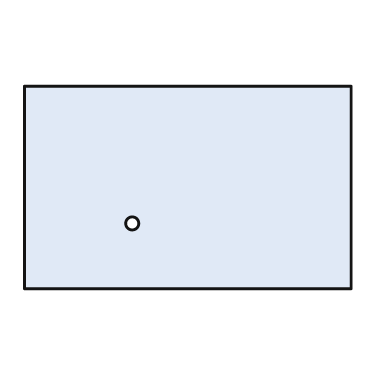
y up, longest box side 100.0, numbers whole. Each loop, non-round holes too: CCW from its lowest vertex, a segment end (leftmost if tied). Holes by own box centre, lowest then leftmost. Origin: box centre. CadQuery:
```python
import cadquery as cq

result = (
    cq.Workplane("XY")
    .moveTo(-50.0, -31.0)
    .lineTo(50.0, -31.0)
    .lineTo(50.0, 31.0)
    .lineTo(-50.0, 31.0)
    .close()
    .moveTo(-17.0, -11.0)
    .circle(2.0)
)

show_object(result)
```